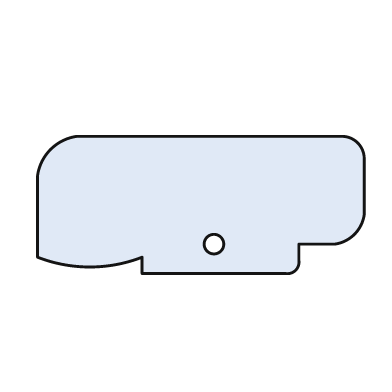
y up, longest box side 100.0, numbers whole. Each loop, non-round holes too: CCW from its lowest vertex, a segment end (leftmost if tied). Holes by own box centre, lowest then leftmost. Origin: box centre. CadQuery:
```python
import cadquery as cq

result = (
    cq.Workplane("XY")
    .moveTo(-18.0, -21.0)
    .lineTo(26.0, -21.0)
    .threePointArc((29.0, -20.0), (30.0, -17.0))
    .lineTo(30.0, -12.0)
    .lineTo(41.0, -12.0)
    .threePointArc((47.0, -9.0), (50.0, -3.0))
    .lineTo(50.0, 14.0)
    .threePointArc((48.0, 19.0), (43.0, 21.0))
    .lineTo(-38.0, 21.0)
    .threePointArc((-46.0, 17.0), (-50.0, 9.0))
    .lineTo(-50.0, -16.0)
    .threePointArc((-34.0, -19.0), (-18.0, -16.0))
    .close()
    .moveTo(4.0, -12.0)
    .circle(3.0)
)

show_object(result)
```